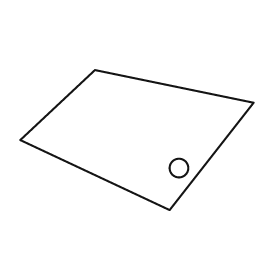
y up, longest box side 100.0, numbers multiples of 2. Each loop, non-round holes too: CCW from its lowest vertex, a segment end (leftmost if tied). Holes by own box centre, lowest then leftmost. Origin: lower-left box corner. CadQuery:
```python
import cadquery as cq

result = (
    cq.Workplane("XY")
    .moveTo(64.0, 0.0)
    .lineTo(100.0, 46.0)
    .lineTo(32.0, 60.0)
    .lineTo(0.0, 30.0)
    .close()
    .moveTo(68.0, 18.0)
    .circle(4.0)
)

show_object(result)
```